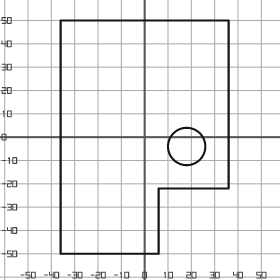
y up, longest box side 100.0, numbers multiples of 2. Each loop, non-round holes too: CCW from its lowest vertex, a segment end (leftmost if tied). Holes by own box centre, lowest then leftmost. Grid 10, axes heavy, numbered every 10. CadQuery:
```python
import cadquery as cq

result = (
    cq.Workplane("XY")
    .moveTo(-36.0, -50.0)
    .lineTo(6.0, -50.0)
    .lineTo(6.0, -22.0)
    .lineTo(36.0, -22.0)
    .lineTo(36.0, 50.0)
    .lineTo(-36.0, 50.0)
    .close()
    .moveTo(18.0, -4.0)
    .circle(8.0)
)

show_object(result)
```